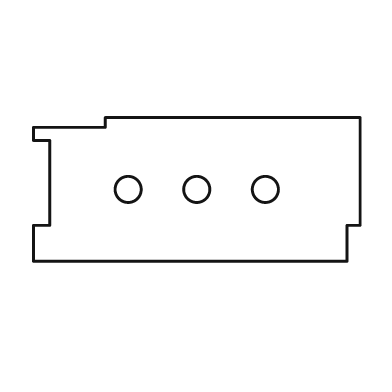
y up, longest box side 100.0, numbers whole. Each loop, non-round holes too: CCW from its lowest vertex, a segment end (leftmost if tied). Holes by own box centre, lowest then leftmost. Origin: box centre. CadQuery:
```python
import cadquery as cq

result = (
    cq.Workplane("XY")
    .moveTo(-50.0, -22.0)
    .lineTo(46.0, -22.0)
    .lineTo(46.0, -11.0)
    .lineTo(50.0, -11.0)
    .lineTo(50.0, 22.0)
    .lineTo(-28.0, 22.0)
    .lineTo(-28.0, 19.0)
    .lineTo(-50.0, 19.0)
    .lineTo(-50.0, 15.0)
    .lineTo(-45.0, 15.0)
    .lineTo(-45.0, -11.0)
    .lineTo(-50.0, -11.0)
    .close()
    .moveTo(-21.0, 0.0)
    .circle(4.0)
    .moveTo(0.0, 0.0)
    .circle(4.0)
    .moveTo(21.0, 0.0)
    .circle(4.0)
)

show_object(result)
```